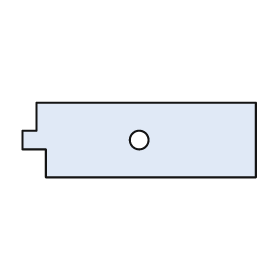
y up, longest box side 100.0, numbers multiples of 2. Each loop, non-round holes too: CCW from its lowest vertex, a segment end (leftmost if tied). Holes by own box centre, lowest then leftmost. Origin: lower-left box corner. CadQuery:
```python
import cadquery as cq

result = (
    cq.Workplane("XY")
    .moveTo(10.0, 0.0)
    .lineTo(100.0, 0.0)
    .lineTo(100.0, 32.0)
    .lineTo(6.0, 32.0)
    .lineTo(6.0, 20.0)
    .lineTo(0.0, 20.0)
    .lineTo(0.0, 12.0)
    .lineTo(10.0, 12.0)
    .close()
    .moveTo(50.0, 16.0)
    .circle(4.0)
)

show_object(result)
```